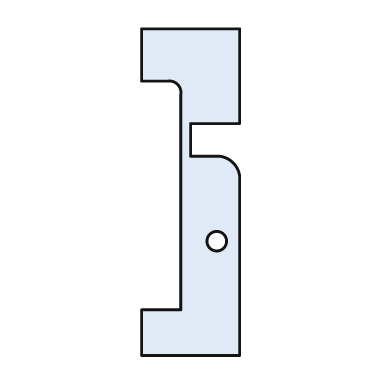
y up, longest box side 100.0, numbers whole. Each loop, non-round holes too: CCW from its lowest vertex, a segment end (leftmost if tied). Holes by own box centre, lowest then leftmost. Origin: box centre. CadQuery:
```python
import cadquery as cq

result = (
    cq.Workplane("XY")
    .moveTo(-15.0, -50.0)
    .lineTo(15.0, -50.0)
    .lineTo(15.0, 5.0)
    .threePointArc((13.0, 9.0), (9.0, 11.0))
    .lineTo(0.0, 11.0)
    .lineTo(0.0, 21.0)
    .lineTo(15.0, 21.0)
    .lineTo(15.0, 50.0)
    .lineTo(-15.0, 50.0)
    .lineTo(-15.0, 34.0)
    .lineTo(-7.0, 34.0)
    .threePointArc((-4.0, 33.0), (-3.0, 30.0))
    .lineTo(-3.0, -36.0)
    .lineTo(-15.0, -36.0)
    .close()
    .moveTo(8.0, -15.0)
    .circle(3.0)
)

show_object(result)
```